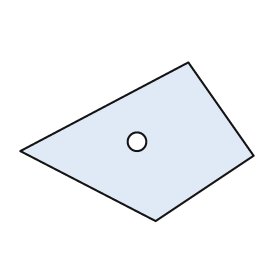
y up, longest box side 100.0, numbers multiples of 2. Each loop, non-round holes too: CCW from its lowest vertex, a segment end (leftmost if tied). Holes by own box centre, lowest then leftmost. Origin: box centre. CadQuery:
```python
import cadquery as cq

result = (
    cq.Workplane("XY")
    .moveTo(8.0, -34.0)
    .lineTo(50.0, -6.0)
    .lineTo(22.0, 34.0)
    .lineTo(-50.0, -4.0)
    .close()
    .moveTo(0.0, 0.0)
    .circle(4.0)
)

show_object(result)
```